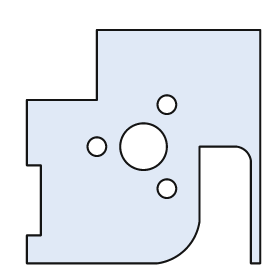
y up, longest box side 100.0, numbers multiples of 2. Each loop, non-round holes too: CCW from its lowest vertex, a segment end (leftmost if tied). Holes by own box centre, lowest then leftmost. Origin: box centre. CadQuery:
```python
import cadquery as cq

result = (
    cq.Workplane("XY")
    .moveTo(-50.0, -50.0)
    .lineTo(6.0, -50.0)
    .threePointArc((18.0, -44.0), (24.0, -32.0))
    .lineTo(24.0, 0.0)
    .lineTo(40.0, 0.0)
    .threePointArc((44.0, -2.0), (46.0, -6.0))
    .lineTo(46.0, -50.0)
    .lineTo(50.0, -50.0)
    .lineTo(50.0, 50.0)
    .lineTo(-20.0, 50.0)
    .lineTo(-20.0, 20.0)
    .lineTo(-50.0, 20.0)
    .lineTo(-50.0, -8.0)
    .lineTo(-44.0, -8.0)
    .lineTo(-44.0, -38.0)
    .lineTo(-50.0, -38.0)
    .close()
    .moveTo(10.0, -18.0)
    .circle(4.0)
    .moveTo(-20.0, 0.0)
    .circle(4.0)
    .moveTo(0.0, 0.0)
    .circle(10.0)
    .moveTo(10.0, 18.0)
    .circle(4.0)
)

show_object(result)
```